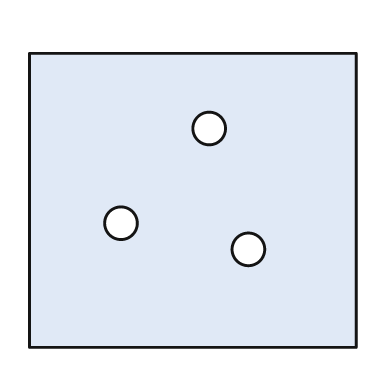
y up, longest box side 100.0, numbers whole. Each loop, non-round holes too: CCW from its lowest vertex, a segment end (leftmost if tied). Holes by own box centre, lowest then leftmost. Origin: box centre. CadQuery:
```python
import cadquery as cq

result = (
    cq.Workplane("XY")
    .moveTo(-50.0, -45.0)
    .lineTo(50.0, -45.0)
    .lineTo(50.0, 45.0)
    .lineTo(-50.0, 45.0)
    .close()
    .moveTo(17.0, -15.0)
    .circle(5.0)
    .moveTo(-22.0, -7.0)
    .circle(5.0)
    .moveTo(5.0, 22.0)
    .circle(5.0)
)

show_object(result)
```